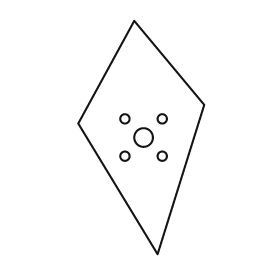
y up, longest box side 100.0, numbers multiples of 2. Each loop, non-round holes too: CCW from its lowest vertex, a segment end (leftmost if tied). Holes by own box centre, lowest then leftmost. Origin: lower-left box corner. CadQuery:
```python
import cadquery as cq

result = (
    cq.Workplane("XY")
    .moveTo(34.0, 0.0)
    .lineTo(54.0, 64.0)
    .lineTo(24.0, 100.0)
    .lineTo(0.0, 56.0)
    .close()
    .moveTo(20.0, 42.0)
    .circle(2.0)
    .moveTo(36.0, 42.0)
    .circle(2.0)
    .moveTo(28.0, 50.0)
    .circle(4.0)
    .moveTo(20.0, 58.0)
    .circle(2.0)
    .moveTo(36.0, 58.0)
    .circle(2.0)
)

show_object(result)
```